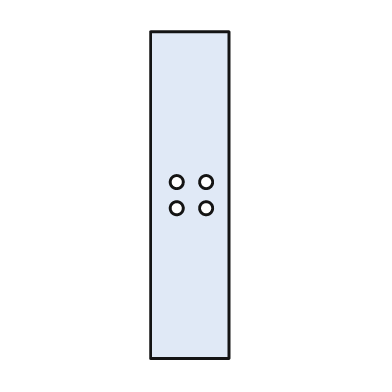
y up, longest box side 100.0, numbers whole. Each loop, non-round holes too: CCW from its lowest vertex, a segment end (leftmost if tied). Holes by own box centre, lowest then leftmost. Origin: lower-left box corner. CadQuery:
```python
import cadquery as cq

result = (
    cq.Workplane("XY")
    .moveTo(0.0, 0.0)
    .lineTo(24.0, 0.0)
    .lineTo(24.0, 100.0)
    .lineTo(0.0, 100.0)
    .close()
    .moveTo(8.0, 46.0)
    .circle(2.0)
    .moveTo(17.0, 46.0)
    .circle(2.0)
    .moveTo(8.0, 54.0)
    .circle(2.0)
    .moveTo(17.0, 54.0)
    .circle(2.0)
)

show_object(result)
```